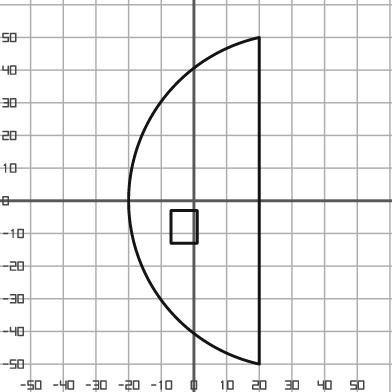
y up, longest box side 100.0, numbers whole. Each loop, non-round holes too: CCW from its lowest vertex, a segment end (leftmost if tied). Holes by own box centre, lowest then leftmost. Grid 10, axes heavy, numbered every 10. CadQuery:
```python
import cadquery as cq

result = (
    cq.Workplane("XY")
    .moveTo(20.0, -50.0)
    .lineTo(20.0, 50.0)
    .threePointArc((-20.0, 0.0), (20.0, -50.0))
    .close()
    .moveTo(-7.0, -13.0)
    .lineTo(1.0, -13.0)
    .lineTo(1.0, -3.0)
    .lineTo(-7.0, -3.0)
    .close()
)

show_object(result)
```